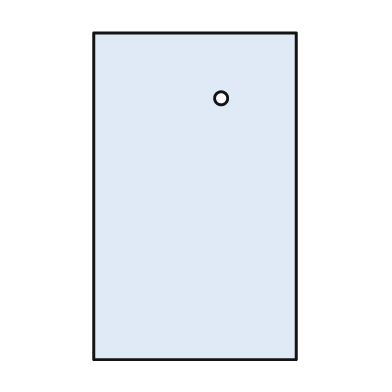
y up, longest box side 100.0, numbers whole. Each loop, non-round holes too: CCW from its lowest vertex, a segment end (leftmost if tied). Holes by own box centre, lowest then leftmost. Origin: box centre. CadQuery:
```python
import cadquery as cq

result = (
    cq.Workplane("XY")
    .moveTo(-31.0, -50.0)
    .lineTo(31.0, -50.0)
    .lineTo(31.0, 50.0)
    .lineTo(-31.0, 50.0)
    .close()
    .moveTo(8.0, 30.0)
    .circle(2.0)
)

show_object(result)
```